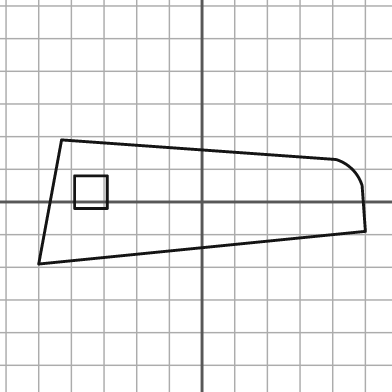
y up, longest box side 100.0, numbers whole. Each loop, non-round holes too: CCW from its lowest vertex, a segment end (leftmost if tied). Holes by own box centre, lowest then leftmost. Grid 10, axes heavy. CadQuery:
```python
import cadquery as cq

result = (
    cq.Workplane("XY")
    .moveTo(-50.0, -19.0)
    .lineTo(50.0, -9.0)
    .lineTo(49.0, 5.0)
    .threePointArc((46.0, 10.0), (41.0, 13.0))
    .lineTo(-43.0, 19.0)
    .close()
    .moveTo(-39.0, -2.0)
    .lineTo(-29.0, -2.0)
    .lineTo(-29.0, 8.0)
    .lineTo(-39.0, 8.0)
    .close()
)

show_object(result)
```